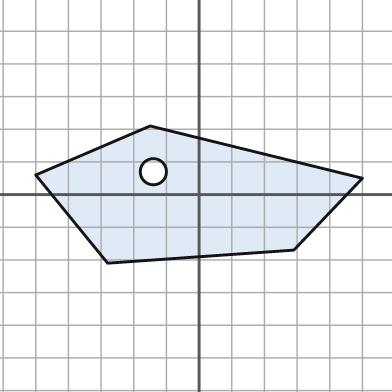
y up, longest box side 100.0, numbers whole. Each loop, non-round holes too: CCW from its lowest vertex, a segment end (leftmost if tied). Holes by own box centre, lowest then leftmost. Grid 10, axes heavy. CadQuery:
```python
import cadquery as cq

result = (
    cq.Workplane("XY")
    .moveTo(-28.0, -21.0)
    .lineTo(29.0, -17.0)
    .lineTo(50.0, 5.0)
    .lineTo(-15.0, 21.0)
    .lineTo(-50.0, 6.0)
    .close()
    .moveTo(-14.0, 7.0)
    .circle(4.0)
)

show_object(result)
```